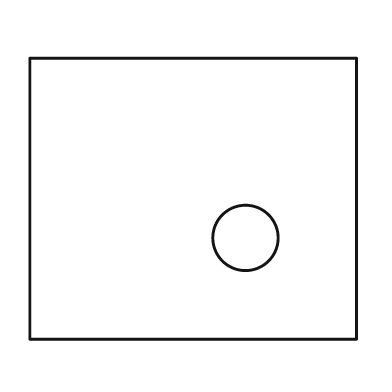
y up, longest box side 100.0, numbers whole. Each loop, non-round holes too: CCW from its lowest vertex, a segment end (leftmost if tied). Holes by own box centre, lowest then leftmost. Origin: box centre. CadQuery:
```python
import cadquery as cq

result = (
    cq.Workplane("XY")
    .moveTo(-50.0, -43.0)
    .lineTo(50.0, -43.0)
    .lineTo(50.0, 43.0)
    .lineTo(-50.0, 43.0)
    .close()
    .moveTo(16.0, -12.0)
    .circle(10.0)
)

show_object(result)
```